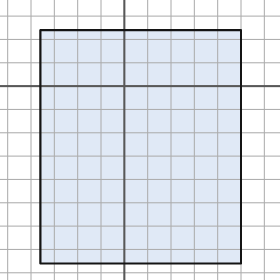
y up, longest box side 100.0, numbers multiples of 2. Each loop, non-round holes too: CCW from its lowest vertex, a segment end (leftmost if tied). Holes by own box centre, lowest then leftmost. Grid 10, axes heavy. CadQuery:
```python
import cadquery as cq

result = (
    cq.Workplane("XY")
    .moveTo(-36.0, -76.0)
    .lineTo(50.0, -76.0)
    .lineTo(50.0, 24.0)
    .lineTo(-36.0, 24.0)
    .close()
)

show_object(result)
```